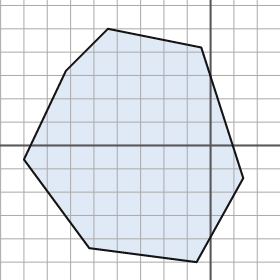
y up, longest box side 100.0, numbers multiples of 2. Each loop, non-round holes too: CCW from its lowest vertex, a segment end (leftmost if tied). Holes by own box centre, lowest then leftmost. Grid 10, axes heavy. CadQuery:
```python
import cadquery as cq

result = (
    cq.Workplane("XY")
    .moveTo(-6.0, -50.0)
    .lineTo(14.0, -14.0)
    .lineTo(-4.0, 42.0)
    .lineTo(-44.0, 50.0)
    .lineTo(-62.0, 32.0)
    .lineTo(-80.0, -6.0)
    .lineTo(-52.0, -44.0)
    .close()
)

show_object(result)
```